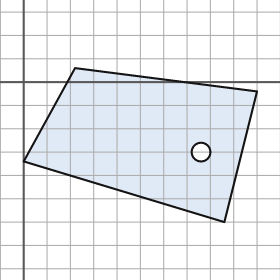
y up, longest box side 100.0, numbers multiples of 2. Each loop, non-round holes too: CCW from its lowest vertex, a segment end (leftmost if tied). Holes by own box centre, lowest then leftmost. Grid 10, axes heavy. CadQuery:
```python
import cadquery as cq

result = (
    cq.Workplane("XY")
    .moveTo(86.0, -60.0)
    .lineTo(100.0, -4.0)
    .lineTo(22.0, 6.0)
    .lineTo(0.0, -34.0)
    .close()
    .moveTo(76.0, -30.0)
    .circle(4.0)
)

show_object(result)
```